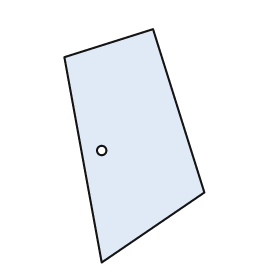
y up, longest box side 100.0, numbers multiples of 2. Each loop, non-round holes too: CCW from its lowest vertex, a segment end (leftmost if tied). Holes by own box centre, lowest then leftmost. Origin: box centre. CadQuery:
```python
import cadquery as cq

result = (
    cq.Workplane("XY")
    .moveTo(-14.0, -50.0)
    .lineTo(30.0, -20.0)
    .lineTo(8.0, 50.0)
    .lineTo(-30.0, 38.0)
    .close()
    .moveTo(-14.0, -2.0)
    .circle(2.0)
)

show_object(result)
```